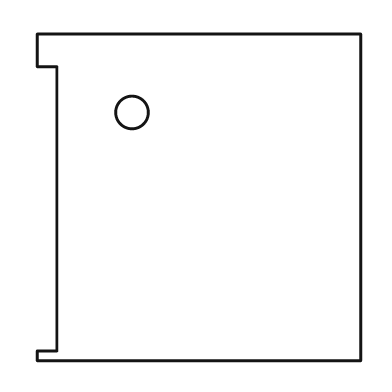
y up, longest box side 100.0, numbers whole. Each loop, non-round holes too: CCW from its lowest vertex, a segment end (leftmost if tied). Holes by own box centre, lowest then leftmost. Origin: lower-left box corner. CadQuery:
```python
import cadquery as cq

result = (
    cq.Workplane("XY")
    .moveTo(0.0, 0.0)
    .lineTo(99.0, 0.0)
    .lineTo(99.0, 100.0)
    .lineTo(0.0, 100.0)
    .lineTo(0.0, 90.0)
    .lineTo(6.0, 90.0)
    .lineTo(6.0, 3.0)
    .lineTo(0.0, 3.0)
    .close()
    .moveTo(29.0, 76.0)
    .circle(5.0)
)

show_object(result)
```